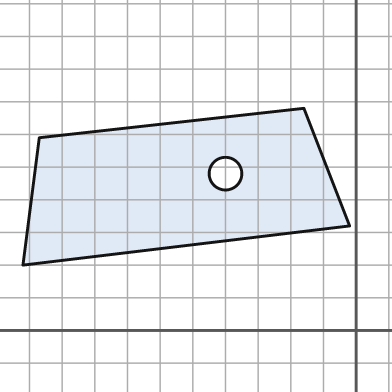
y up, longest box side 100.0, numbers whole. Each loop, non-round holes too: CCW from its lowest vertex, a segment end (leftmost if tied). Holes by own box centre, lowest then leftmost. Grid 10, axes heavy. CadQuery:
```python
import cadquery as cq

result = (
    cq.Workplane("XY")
    .moveTo(-102.0, 20.0)
    .lineTo(-2.0, 32.0)
    .lineTo(-16.0, 68.0)
    .lineTo(-97.0, 59.0)
    .close()
    .moveTo(-40.0, 48.0)
    .circle(5.0)
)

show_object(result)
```